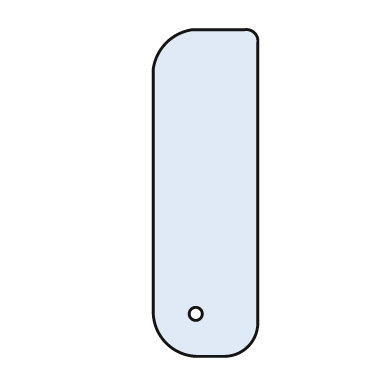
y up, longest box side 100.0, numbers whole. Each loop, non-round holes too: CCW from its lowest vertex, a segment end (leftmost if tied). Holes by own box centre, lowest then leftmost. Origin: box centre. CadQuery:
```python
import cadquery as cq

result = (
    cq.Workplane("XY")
    .moveTo(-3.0, -50.0)
    .lineTo(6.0, -50.0)
    .threePointArc((13.0, -47.0), (16.0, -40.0))
    .lineTo(16.0, 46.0)
    .threePointArc((15.0, 49.0), (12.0, 50.0))
    .lineTo(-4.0, 50.0)
    .threePointArc((-12.0, 46.0), (-16.0, 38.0))
    .lineTo(-16.0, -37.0)
    .threePointArc((-12.0, -46.0), (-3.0, -50.0))
    .close()
    .moveTo(-3.0, -37.0)
    .circle(2.0)
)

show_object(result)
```